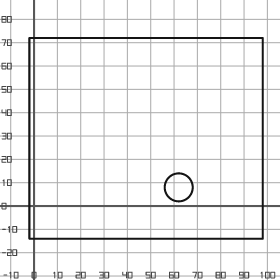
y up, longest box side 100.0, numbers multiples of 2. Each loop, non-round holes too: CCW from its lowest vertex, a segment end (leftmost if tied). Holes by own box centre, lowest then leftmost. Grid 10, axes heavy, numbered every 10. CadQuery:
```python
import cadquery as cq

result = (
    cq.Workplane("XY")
    .moveTo(-2.0, -14.0)
    .lineTo(98.0, -14.0)
    .lineTo(98.0, 72.0)
    .lineTo(-2.0, 72.0)
    .close()
    .moveTo(62.0, 8.0)
    .circle(6.0)
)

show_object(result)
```